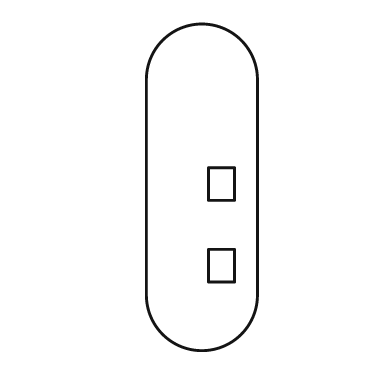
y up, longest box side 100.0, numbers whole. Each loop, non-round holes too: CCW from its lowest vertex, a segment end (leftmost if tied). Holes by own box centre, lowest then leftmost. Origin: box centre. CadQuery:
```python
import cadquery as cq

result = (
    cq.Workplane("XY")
    .moveTo(-17.0, -33.0)
    .threePointArc((0.0, -50.0), (17.0, -33.0))
    .lineTo(17.0, 33.0)
    .threePointArc((0.0, 50.0), (-17.0, 33.0))
    .close()
    .moveTo(2.0, -29.0)
    .lineTo(10.0, -29.0)
    .lineTo(10.0, -19.0)
    .lineTo(2.0, -19.0)
    .close()
    .moveTo(2.0, -4.0)
    .lineTo(10.0, -4.0)
    .lineTo(10.0, 6.0)
    .lineTo(2.0, 6.0)
    .close()
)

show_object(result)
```